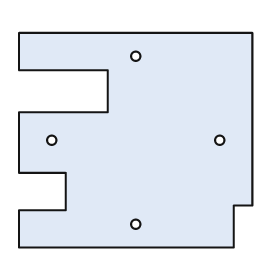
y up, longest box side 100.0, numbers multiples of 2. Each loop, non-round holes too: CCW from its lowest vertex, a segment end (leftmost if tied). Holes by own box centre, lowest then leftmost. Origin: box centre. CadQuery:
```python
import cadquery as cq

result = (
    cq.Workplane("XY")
    .moveTo(-50.0, -46.0)
    .lineTo(42.0, -46.0)
    .lineTo(42.0, -28.0)
    .lineTo(50.0, -28.0)
    .lineTo(50.0, 46.0)
    .lineTo(-50.0, 46.0)
    .lineTo(-50.0, 30.0)
    .lineTo(-12.0, 30.0)
    .lineTo(-12.0, 12.0)
    .lineTo(-50.0, 12.0)
    .lineTo(-50.0, -14.0)
    .lineTo(-30.0, -14.0)
    .lineTo(-30.0, -30.0)
    .lineTo(-50.0, -30.0)
    .close()
    .moveTo(0.0, -36.0)
    .circle(2.0)
    .moveTo(-36.0, 0.0)
    .circle(2.0)
    .moveTo(36.0, 0.0)
    .circle(2.0)
    .moveTo(0.0, 36.0)
    .circle(2.0)
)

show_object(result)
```